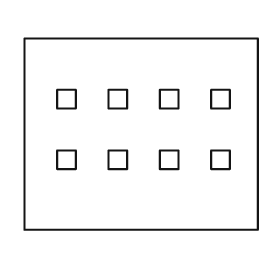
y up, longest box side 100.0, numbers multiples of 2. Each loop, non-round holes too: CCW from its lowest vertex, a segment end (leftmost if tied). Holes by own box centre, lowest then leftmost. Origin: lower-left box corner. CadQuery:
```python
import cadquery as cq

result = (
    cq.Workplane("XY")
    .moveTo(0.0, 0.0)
    .lineTo(100.0, 0.0)
    .lineTo(100.0, 82.0)
    .lineTo(0.0, 82.0)
    .close()
    .moveTo(14.0, 26.0)
    .lineTo(22.0, 26.0)
    .lineTo(22.0, 34.0)
    .lineTo(14.0, 34.0)
    .close()
    .moveTo(36.0, 26.0)
    .lineTo(44.0, 26.0)
    .lineTo(44.0, 34.0)
    .lineTo(36.0, 34.0)
    .close()
    .moveTo(58.0, 26.0)
    .lineTo(66.0, 26.0)
    .lineTo(66.0, 34.0)
    .lineTo(58.0, 34.0)
    .close()
    .moveTo(80.0, 26.0)
    .lineTo(88.0, 26.0)
    .lineTo(88.0, 34.0)
    .lineTo(80.0, 34.0)
    .close()
    .moveTo(14.0, 52.0)
    .lineTo(22.0, 52.0)
    .lineTo(22.0, 60.0)
    .lineTo(14.0, 60.0)
    .close()
    .moveTo(36.0, 52.0)
    .lineTo(44.0, 52.0)
    .lineTo(44.0, 60.0)
    .lineTo(36.0, 60.0)
    .close()
    .moveTo(58.0, 52.0)
    .lineTo(66.0, 52.0)
    .lineTo(66.0, 60.0)
    .lineTo(58.0, 60.0)
    .close()
    .moveTo(80.0, 52.0)
    .lineTo(88.0, 52.0)
    .lineTo(88.0, 60.0)
    .lineTo(80.0, 60.0)
    .close()
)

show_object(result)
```